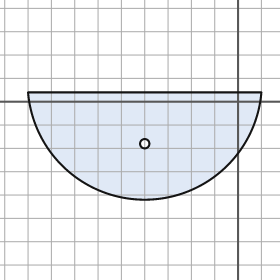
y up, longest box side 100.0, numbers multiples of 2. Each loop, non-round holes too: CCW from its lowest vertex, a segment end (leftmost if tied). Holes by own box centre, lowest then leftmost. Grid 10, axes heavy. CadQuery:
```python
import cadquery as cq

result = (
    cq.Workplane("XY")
    .moveTo(-90.0, 4.0)
    .threePointArc((-40.0, -42.0), (10.0, 4.0))
    .close()
    .moveTo(-40.0, -18.0)
    .circle(2.0)
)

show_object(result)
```